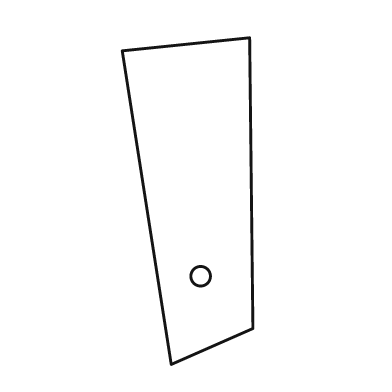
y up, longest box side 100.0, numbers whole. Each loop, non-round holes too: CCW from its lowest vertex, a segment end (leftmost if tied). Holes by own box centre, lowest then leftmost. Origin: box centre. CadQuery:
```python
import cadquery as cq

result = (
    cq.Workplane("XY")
    .moveTo(-5.0, -50.0)
    .lineTo(20.0, -39.0)
    .lineTo(19.0, 50.0)
    .lineTo(-20.0, 46.0)
    .close()
    .moveTo(4.0, -23.0)
    .circle(3.0)
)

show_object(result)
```